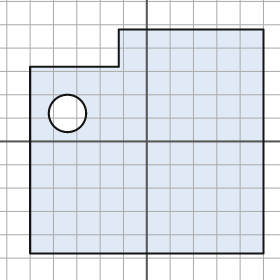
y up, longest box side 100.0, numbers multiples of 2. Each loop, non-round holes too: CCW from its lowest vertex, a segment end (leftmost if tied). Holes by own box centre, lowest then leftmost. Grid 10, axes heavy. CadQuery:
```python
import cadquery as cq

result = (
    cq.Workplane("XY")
    .moveTo(-50.0, -48.0)
    .lineTo(50.0, -48.0)
    .lineTo(50.0, 48.0)
    .lineTo(-12.0, 48.0)
    .lineTo(-12.0, 32.0)
    .lineTo(-50.0, 32.0)
    .close()
    .moveTo(-34.0, 12.0)
    .circle(8.0)
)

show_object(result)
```